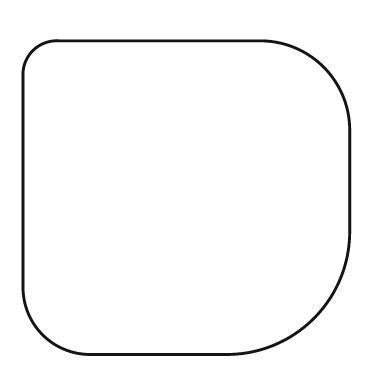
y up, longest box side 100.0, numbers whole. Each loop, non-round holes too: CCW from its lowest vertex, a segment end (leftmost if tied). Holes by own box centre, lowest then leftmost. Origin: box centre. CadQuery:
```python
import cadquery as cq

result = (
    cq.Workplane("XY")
    .moveTo(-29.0, -48.0)
    .lineTo(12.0, -48.0)
    .threePointArc((39.0, -37.0), (50.0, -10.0))
    .lineTo(50.0, 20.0)
    .threePointArc((42.0, 40.0), (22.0, 48.0))
    .lineTo(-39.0, 48.0)
    .threePointArc((-47.0, 45.0), (-50.0, 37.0))
    .lineTo(-50.0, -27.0)
    .threePointArc((-44.0, -42.0), (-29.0, -48.0))
    .close()
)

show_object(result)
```